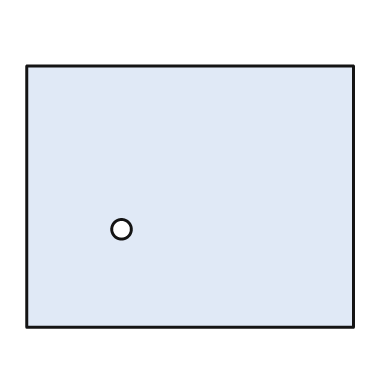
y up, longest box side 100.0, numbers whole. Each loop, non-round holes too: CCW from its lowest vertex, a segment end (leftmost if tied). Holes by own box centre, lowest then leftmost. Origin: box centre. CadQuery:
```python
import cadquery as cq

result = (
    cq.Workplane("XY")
    .moveTo(-50.0, -40.0)
    .lineTo(50.0, -40.0)
    .lineTo(50.0, 40.0)
    .lineTo(-50.0, 40.0)
    .close()
    .moveTo(-21.0, -10.0)
    .circle(3.0)
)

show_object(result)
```